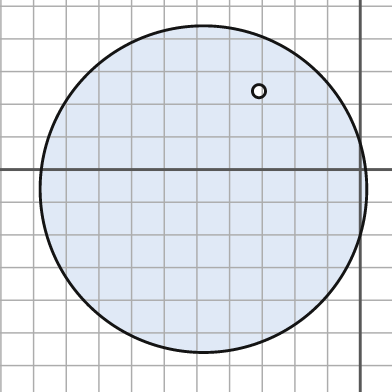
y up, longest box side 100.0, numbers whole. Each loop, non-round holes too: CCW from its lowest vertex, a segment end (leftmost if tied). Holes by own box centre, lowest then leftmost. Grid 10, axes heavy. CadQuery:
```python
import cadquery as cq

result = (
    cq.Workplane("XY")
    .moveTo(-48.0, -6.0)
    .circle(50.0)
    .moveTo(-31.0, 24.0)
    .circle(2.0)
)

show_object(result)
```